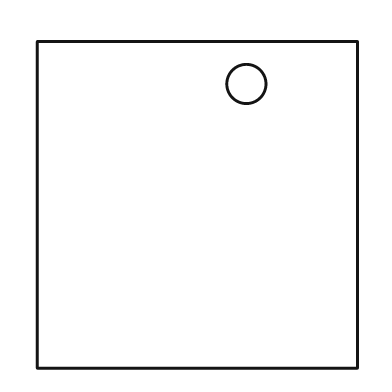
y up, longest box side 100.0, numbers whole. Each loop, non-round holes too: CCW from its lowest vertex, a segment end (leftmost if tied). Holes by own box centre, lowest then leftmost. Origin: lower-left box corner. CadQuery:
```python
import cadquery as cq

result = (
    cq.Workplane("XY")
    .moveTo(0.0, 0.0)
    .lineTo(98.0, 0.0)
    .lineTo(98.0, 100.0)
    .lineTo(0.0, 100.0)
    .close()
    .moveTo(64.0, 87.0)
    .circle(6.0)
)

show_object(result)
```